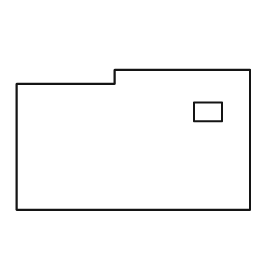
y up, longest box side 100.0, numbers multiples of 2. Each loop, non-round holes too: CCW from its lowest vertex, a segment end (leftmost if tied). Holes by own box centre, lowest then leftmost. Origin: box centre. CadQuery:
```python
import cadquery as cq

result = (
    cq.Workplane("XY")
    .moveTo(-50.0, -30.0)
    .lineTo(50.0, -30.0)
    .lineTo(50.0, 30.0)
    .lineTo(-8.0, 30.0)
    .lineTo(-8.0, 24.0)
    .lineTo(-50.0, 24.0)
    .close()
    .moveTo(26.0, 8.0)
    .lineTo(38.0, 8.0)
    .lineTo(38.0, 16.0)
    .lineTo(26.0, 16.0)
    .close()
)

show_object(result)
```